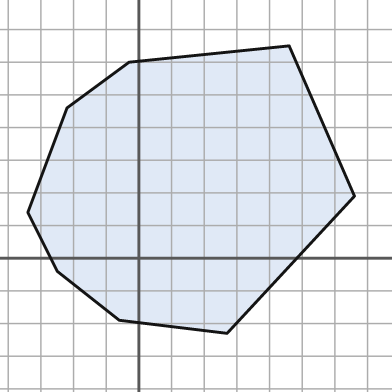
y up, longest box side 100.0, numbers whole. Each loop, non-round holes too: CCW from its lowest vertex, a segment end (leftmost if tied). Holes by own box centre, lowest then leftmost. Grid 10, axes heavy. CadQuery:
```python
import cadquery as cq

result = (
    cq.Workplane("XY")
    .moveTo(27.0, -23.0)
    .lineTo(66.0, 19.0)
    .lineTo(46.0, 65.0)
    .lineTo(-3.0, 60.0)
    .lineTo(-22.0, 46.0)
    .lineTo(-34.0, 14.0)
    .lineTo(-25.0, -4.0)
    .lineTo(-6.0, -19.0)
    .close()
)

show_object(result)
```